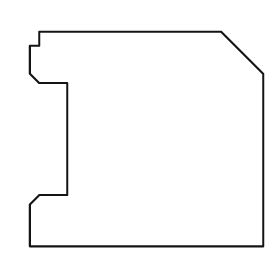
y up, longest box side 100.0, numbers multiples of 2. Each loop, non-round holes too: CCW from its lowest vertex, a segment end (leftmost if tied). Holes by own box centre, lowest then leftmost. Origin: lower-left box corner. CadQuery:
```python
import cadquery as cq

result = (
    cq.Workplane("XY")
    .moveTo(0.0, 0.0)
    .lineTo(100.0, 0.0)
    .lineTo(100.0, 74.0)
    .lineTo(82.0, 92.0)
    .lineTo(4.0, 92.0)
    .lineTo(4.0, 86.0)
    .lineTo(0.0, 86.0)
    .lineTo(0.0, 74.0)
    .lineTo(4.0, 70.0)
    .lineTo(16.0, 70.0)
    .lineTo(16.0, 22.0)
    .lineTo(4.0, 22.0)
    .lineTo(0.0, 18.0)
    .close()
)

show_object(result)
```